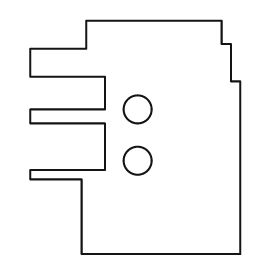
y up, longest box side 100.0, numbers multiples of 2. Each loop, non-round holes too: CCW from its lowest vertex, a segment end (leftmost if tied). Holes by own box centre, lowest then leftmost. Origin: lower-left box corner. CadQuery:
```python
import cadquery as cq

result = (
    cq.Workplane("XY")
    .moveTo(22.0, 0.0)
    .lineTo(90.0, 0.0)
    .lineTo(90.0, 74.0)
    .lineTo(86.0, 74.0)
    .lineTo(86.0, 90.0)
    .lineTo(82.0, 90.0)
    .lineTo(82.0, 100.0)
    .lineTo(24.0, 100.0)
    .lineTo(24.0, 88.0)
    .lineTo(0.0, 88.0)
    .lineTo(0.0, 76.0)
    .lineTo(32.0, 76.0)
    .lineTo(32.0, 62.0)
    .lineTo(0.0, 62.0)
    .lineTo(0.0, 56.0)
    .lineTo(32.0, 56.0)
    .lineTo(32.0, 36.0)
    .lineTo(0.0, 36.0)
    .lineTo(0.0, 32.0)
    .lineTo(22.0, 32.0)
    .close()
    .moveTo(46.0, 40.0)
    .circle(6.0)
    .moveTo(46.0, 62.0)
    .circle(6.0)
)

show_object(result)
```